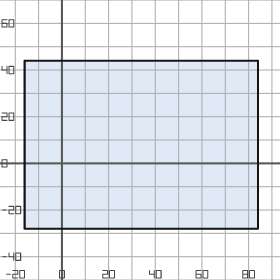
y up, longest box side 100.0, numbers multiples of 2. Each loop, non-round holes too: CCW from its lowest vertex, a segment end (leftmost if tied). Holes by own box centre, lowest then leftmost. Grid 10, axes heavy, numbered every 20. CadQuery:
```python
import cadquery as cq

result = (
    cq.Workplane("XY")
    .moveTo(-16.0, -28.0)
    .lineTo(84.0, -28.0)
    .lineTo(84.0, 44.0)
    .lineTo(-16.0, 44.0)
    .close()
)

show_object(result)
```